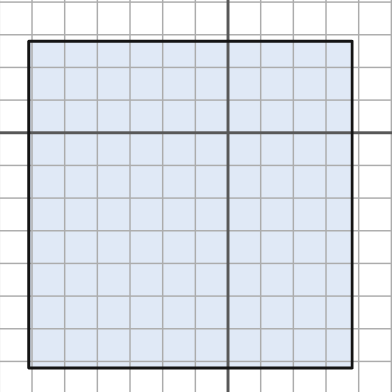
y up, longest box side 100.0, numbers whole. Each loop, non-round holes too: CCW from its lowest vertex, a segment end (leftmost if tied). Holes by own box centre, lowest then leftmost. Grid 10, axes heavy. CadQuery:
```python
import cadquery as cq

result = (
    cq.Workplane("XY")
    .moveTo(-61.0, -72.0)
    .lineTo(38.0, -72.0)
    .lineTo(38.0, 28.0)
    .lineTo(-61.0, 28.0)
    .close()
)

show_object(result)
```